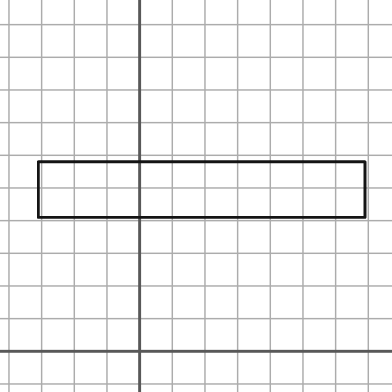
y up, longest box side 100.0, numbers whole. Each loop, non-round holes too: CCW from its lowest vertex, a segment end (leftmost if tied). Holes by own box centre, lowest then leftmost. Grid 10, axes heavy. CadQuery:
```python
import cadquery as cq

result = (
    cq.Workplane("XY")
    .moveTo(-31.0, 41.0)
    .lineTo(69.0, 41.0)
    .lineTo(69.0, 58.0)
    .lineTo(-31.0, 58.0)
    .close()
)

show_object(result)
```